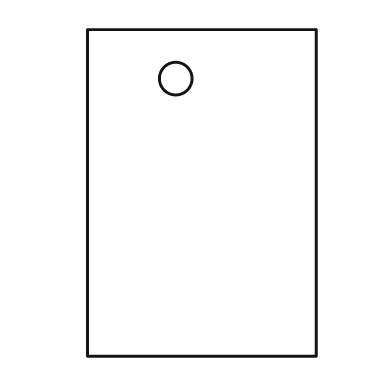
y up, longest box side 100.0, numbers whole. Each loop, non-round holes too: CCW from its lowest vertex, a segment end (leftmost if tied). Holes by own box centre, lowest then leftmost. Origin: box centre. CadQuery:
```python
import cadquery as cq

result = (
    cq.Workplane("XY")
    .moveTo(-35.0, -50.0)
    .lineTo(35.0, -50.0)
    .lineTo(35.0, 50.0)
    .lineTo(-35.0, 50.0)
    .close()
    .moveTo(-8.0, 35.0)
    .circle(5.0)
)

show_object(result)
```